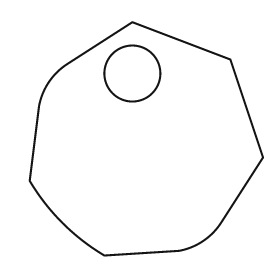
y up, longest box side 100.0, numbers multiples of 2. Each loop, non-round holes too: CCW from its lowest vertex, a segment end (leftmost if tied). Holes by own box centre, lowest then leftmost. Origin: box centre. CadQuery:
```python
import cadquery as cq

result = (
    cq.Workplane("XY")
    .moveTo(-18.0, -50.0)
    .lineTo(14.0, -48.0)
    .threePointArc((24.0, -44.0), (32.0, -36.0))
    .lineTo(50.0, -8.0)
    .lineTo(36.0, 34.0)
    .lineTo(-6.0, 50.0)
    .lineTo(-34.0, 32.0)
    .threePointArc((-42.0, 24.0), (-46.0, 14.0))
    .lineTo(-50.0, -18.0)
    .threePointArc((-36.0, -36.0), (-18.0, -50.0))
    .close()
    .moveTo(-6.0, 28.0)
    .circle(12.0)
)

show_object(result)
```